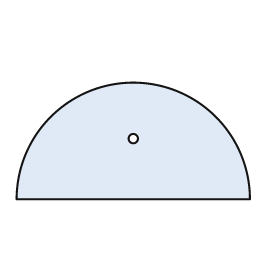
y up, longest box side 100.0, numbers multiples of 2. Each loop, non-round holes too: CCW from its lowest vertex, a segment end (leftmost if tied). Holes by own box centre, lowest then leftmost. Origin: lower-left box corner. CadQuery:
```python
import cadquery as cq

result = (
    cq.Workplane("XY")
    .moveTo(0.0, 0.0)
    .lineTo(100.0, 0.0)
    .threePointArc((50.0, 50.0), (0.0, 0.0))
    .close()
    .moveTo(50.0, 26.0)
    .circle(2.0)
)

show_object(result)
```